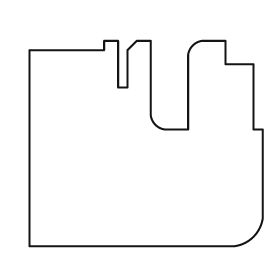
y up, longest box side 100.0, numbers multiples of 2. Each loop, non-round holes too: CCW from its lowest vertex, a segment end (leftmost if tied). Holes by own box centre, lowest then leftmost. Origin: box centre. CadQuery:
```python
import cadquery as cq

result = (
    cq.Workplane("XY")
    .moveTo(-50.0, -44.0)
    .lineTo(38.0, -44.0)
    .threePointArc((46.0, -40.0), (50.0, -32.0))
    .lineTo(50.0, 6.0)
    .lineTo(46.0, 6.0)
    .lineTo(46.0, 34.0)
    .lineTo(34.0, 34.0)
    .lineTo(34.0, 44.0)
    .lineTo(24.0, 44.0)
    .threePointArc((20.0, 42.0), (18.0, 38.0))
    .lineTo(18.0, 6.0)
    .lineTo(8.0, 6.0)
    .threePointArc((4.0, 8.0), (2.0, 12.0))
    .lineTo(2.0, 44.0)
    .lineTo(-4.0, 44.0)
    .lineTo(-8.0, 40.0)
    .lineTo(-8.0, 24.0)
    .lineTo(-12.0, 24.0)
    .lineTo(-12.0, 44.0)
    .lineTo(-18.0, 44.0)
    .lineTo(-18.0, 40.0)
    .lineTo(-50.0, 40.0)
    .close()
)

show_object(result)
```